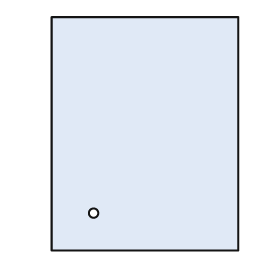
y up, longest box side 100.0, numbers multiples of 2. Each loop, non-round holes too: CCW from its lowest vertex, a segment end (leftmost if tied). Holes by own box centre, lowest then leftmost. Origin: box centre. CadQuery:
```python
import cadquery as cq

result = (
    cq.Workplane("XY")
    .moveTo(-40.0, -50.0)
    .lineTo(40.0, -50.0)
    .lineTo(40.0, 50.0)
    .lineTo(-40.0, 50.0)
    .close()
    .moveTo(-22.0, -34.0)
    .circle(2.0)
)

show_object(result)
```